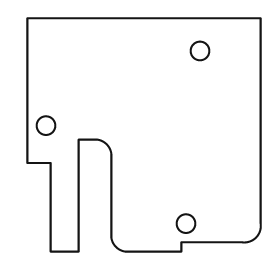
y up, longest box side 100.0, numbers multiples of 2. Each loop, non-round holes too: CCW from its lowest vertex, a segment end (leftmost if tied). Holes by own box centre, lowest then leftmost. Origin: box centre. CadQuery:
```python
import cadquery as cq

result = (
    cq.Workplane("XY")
    .moveTo(-40.0, -50.0)
    .lineTo(-28.0, -50.0)
    .lineTo(-28.0, -2.0)
    .lineTo(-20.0, -2.0)
    .threePointArc((-16.0, -4.0), (-14.0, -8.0))
    .lineTo(-14.0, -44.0)
    .threePointArc((-12.0, -48.0), (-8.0, -50.0))
    .lineTo(16.0, -50.0)
    .lineTo(16.0, -46.0)
    .lineTo(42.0, -46.0)
    .threePointArc((48.0, -44.0), (50.0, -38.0))
    .lineTo(50.0, 50.0)
    .lineTo(-50.0, 50.0)
    .lineTo(-50.0, -12.0)
    .lineTo(-40.0, -12.0)
    .close()
    .moveTo(18.0, -38.0)
    .circle(4.0)
    .moveTo(-42.0, 4.0)
    .circle(4.0)
    .moveTo(24.0, 36.0)
    .circle(4.0)
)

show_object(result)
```